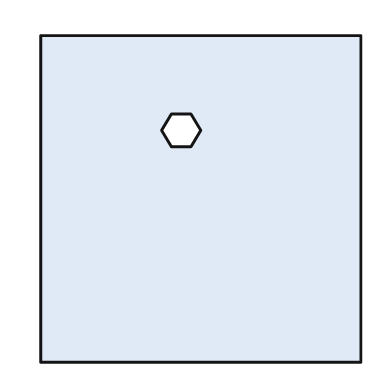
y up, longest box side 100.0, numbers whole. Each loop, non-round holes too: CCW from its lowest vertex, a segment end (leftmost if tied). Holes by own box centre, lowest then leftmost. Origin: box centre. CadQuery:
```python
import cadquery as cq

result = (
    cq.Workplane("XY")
    .moveTo(-49.0, -50.0)
    .lineTo(49.0, -50.0)
    .lineTo(49.0, 50.0)
    .lineTo(-49.0, 50.0)
    .close()
    .moveTo(-9.0, 16.0)
    .lineTo(-3.0, 16.0)
    .lineTo(0.0, 21.0)
    .lineTo(-3.0, 26.0)
    .lineTo(-9.0, 26.0)
    .lineTo(-12.0, 21.0)
    .close()
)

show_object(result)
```